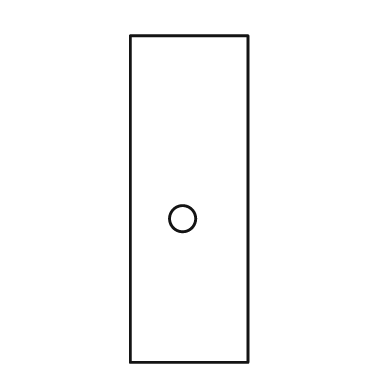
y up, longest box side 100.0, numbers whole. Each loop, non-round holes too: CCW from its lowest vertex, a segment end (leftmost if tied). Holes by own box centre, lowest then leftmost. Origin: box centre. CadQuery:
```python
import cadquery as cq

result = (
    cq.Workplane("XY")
    .moveTo(-18.0, -50.0)
    .lineTo(18.0, -50.0)
    .lineTo(18.0, 50.0)
    .lineTo(-18.0, 50.0)
    .close()
    .moveTo(-2.0, -6.0)
    .circle(4.0)
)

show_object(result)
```